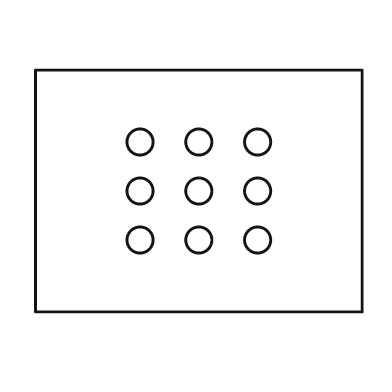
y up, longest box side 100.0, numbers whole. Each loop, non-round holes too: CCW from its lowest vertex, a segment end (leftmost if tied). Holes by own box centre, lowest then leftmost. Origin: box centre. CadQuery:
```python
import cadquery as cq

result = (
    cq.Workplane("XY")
    .moveTo(-50.0, -37.0)
    .lineTo(50.0, -37.0)
    .lineTo(50.0, 37.0)
    .lineTo(-50.0, 37.0)
    .close()
    .moveTo(-18.0, -15.0)
    .circle(4.0)
    .moveTo(0.0, -15.0)
    .circle(4.0)
    .moveTo(18.0, -15.0)
    .circle(4.0)
    .moveTo(-18.0, 0.0)
    .circle(4.0)
    .moveTo(0.0, 0.0)
    .circle(4.0)
    .moveTo(18.0, 0.0)
    .circle(4.0)
    .moveTo(-18.0, 15.0)
    .circle(4.0)
    .moveTo(0.0, 15.0)
    .circle(4.0)
    .moveTo(18.0, 15.0)
    .circle(4.0)
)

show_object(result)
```